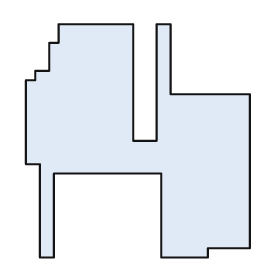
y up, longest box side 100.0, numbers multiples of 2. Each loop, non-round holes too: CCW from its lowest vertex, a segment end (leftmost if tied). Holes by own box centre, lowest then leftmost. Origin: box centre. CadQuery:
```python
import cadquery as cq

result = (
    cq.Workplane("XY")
    .moveTo(-42.0, -50.0)
    .lineTo(-36.0, -50.0)
    .lineTo(-36.0, -14.0)
    .lineTo(10.0, -14.0)
    .lineTo(10.0, -50.0)
    .lineTo(30.0, -50.0)
    .lineTo(30.0, -46.0)
    .lineTo(48.0, -46.0)
    .lineTo(48.0, 20.0)
    .lineTo(14.0, 20.0)
    .lineTo(14.0, 50.0)
    .lineTo(8.0, 50.0)
    .lineTo(8.0, 0.0)
    .lineTo(-2.0, 0.0)
    .lineTo(-2.0, 50.0)
    .lineTo(-34.0, 50.0)
    .lineTo(-34.0, 42.0)
    .lineTo(-38.0, 42.0)
    .lineTo(-38.0, 30.0)
    .lineTo(-44.0, 30.0)
    .lineTo(-44.0, 26.0)
    .lineTo(-48.0, 26.0)
    .lineTo(-48.0, -10.0)
    .lineTo(-42.0, -10.0)
    .close()
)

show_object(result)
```